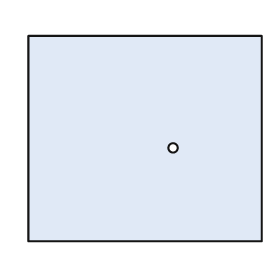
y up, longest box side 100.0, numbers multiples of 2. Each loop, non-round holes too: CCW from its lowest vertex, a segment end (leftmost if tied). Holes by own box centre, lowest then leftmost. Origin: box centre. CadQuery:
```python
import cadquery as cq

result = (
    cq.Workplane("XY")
    .moveTo(-50.0, -44.0)
    .lineTo(50.0, -44.0)
    .lineTo(50.0, 44.0)
    .lineTo(-50.0, 44.0)
    .close()
    .moveTo(12.0, -4.0)
    .circle(2.0)
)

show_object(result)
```